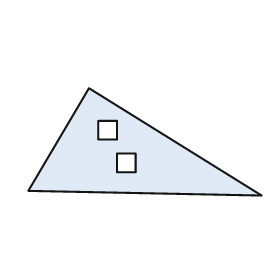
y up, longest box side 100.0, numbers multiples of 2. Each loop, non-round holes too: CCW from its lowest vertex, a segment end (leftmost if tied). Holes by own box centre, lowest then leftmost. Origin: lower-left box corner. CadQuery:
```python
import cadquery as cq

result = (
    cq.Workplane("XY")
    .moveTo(100.0, 0.0)
    .lineTo(26.0, 46.0)
    .lineTo(0.0, 2.0)
    .close()
    .moveTo(38.0, 10.0)
    .lineTo(46.0, 10.0)
    .lineTo(46.0, 18.0)
    .lineTo(38.0, 18.0)
    .close()
    .moveTo(30.0, 24.0)
    .lineTo(38.0, 24.0)
    .lineTo(38.0, 32.0)
    .lineTo(30.0, 32.0)
    .close()
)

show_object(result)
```